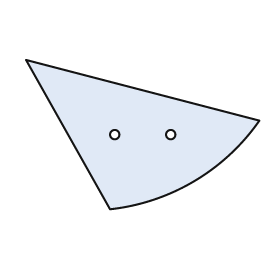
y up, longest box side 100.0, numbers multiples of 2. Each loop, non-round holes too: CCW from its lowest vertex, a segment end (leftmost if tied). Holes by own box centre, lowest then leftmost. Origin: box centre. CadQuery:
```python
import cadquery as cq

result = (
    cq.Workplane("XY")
    .moveTo(-14.0, -32.0)
    .threePointArc((22.0, -20.0), (50.0, 6.0))
    .lineTo(-50.0, 32.0)
    .close()
    .moveTo(-12.0, 0.0)
    .circle(2.0)
    .moveTo(12.0, 0.0)
    .circle(2.0)
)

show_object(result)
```